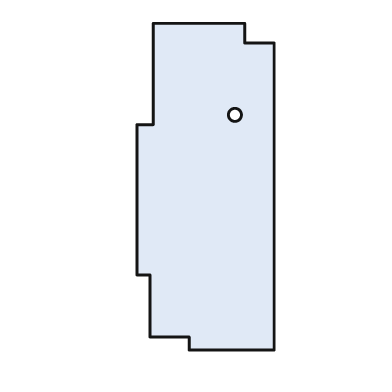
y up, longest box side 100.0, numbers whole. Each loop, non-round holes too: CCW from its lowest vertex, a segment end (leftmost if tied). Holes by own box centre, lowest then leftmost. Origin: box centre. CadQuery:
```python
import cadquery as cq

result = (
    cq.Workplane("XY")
    .moveTo(-5.0, -50.0)
    .lineTo(21.0, -50.0)
    .lineTo(21.0, 44.0)
    .lineTo(12.0, 44.0)
    .lineTo(12.0, 50.0)
    .lineTo(-16.0, 50.0)
    .lineTo(-16.0, 19.0)
    .lineTo(-21.0, 19.0)
    .lineTo(-21.0, -27.0)
    .lineTo(-17.0, -27.0)
    .lineTo(-17.0, -46.0)
    .lineTo(-5.0, -46.0)
    .close()
    .moveTo(9.0, 22.0)
    .circle(2.0)
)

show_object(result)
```